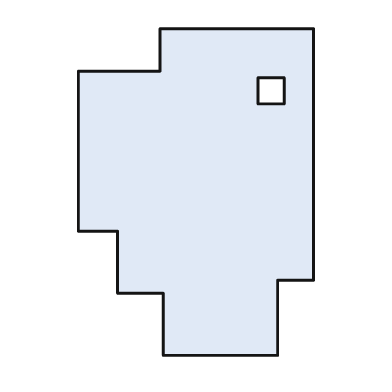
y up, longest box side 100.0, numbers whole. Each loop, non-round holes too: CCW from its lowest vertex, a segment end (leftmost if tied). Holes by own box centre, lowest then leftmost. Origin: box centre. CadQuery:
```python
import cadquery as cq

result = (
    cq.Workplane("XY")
    .moveTo(-10.0, -50.0)
    .lineTo(25.0, -50.0)
    .lineTo(25.0, -27.0)
    .lineTo(36.0, -27.0)
    .lineTo(36.0, 50.0)
    .lineTo(-11.0, 50.0)
    .lineTo(-11.0, 37.0)
    .lineTo(-36.0, 37.0)
    .lineTo(-36.0, -12.0)
    .lineTo(-24.0, -12.0)
    .lineTo(-24.0, -31.0)
    .lineTo(-10.0, -31.0)
    .close()
    .moveTo(19.0, 27.0)
    .lineTo(27.0, 27.0)
    .lineTo(27.0, 35.0)
    .lineTo(19.0, 35.0)
    .close()
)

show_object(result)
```